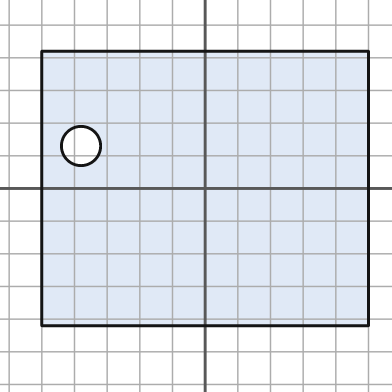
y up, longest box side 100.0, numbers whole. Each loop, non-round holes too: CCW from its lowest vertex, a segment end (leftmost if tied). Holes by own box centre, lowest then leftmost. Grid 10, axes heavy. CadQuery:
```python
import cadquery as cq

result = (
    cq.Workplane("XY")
    .moveTo(-50.0, -42.0)
    .lineTo(50.0, -42.0)
    .lineTo(50.0, 42.0)
    .lineTo(-50.0, 42.0)
    .close()
    .moveTo(-38.0, 13.0)
    .circle(6.0)
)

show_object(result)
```